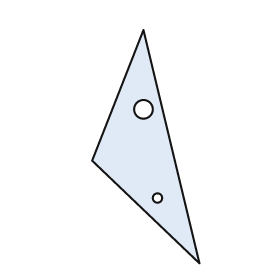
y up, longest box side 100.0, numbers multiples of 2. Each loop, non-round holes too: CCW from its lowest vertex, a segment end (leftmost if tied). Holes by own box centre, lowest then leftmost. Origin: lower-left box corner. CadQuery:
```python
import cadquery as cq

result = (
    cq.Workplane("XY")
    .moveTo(46.0, 0.0)
    .lineTo(22.0, 100.0)
    .lineTo(0.0, 44.0)
    .close()
    .moveTo(28.0, 28.0)
    .circle(2.0)
    .moveTo(22.0, 66.0)
    .circle(4.0)
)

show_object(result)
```